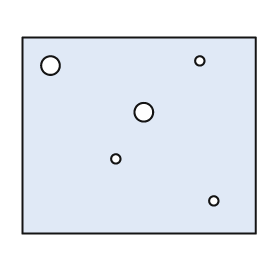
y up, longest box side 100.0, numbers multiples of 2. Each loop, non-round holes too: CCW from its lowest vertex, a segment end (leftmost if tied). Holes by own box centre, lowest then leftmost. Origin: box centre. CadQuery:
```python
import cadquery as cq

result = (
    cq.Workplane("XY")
    .moveTo(-50.0, -42.0)
    .lineTo(50.0, -42.0)
    .lineTo(50.0, 42.0)
    .lineTo(-50.0, 42.0)
    .close()
    .moveTo(32.0, -28.0)
    .circle(2.0)
    .moveTo(-10.0, -10.0)
    .circle(2.0)
    .moveTo(2.0, 10.0)
    .circle(4.0)
    .moveTo(-38.0, 30.0)
    .circle(4.0)
    .moveTo(26.0, 32.0)
    .circle(2.0)
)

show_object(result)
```